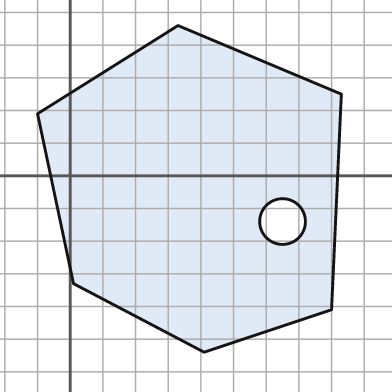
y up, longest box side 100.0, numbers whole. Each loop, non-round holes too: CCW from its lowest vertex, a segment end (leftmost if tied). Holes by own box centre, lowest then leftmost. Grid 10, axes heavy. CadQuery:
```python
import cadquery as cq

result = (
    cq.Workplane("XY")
    .moveTo(41.0, -54.0)
    .lineTo(80.0, -41.0)
    .lineTo(83.0, 25.0)
    .lineTo(33.0, 46.0)
    .lineTo(-10.0, 19.0)
    .lineTo(1.0, -33.0)
    .close()
    .moveTo(65.0, -14.0)
    .circle(7.0)
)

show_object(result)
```